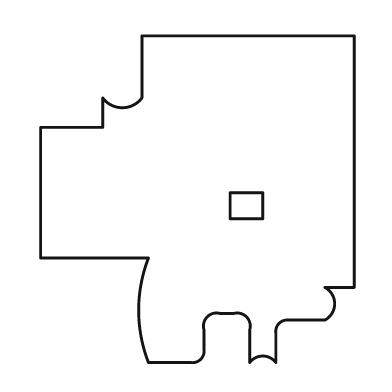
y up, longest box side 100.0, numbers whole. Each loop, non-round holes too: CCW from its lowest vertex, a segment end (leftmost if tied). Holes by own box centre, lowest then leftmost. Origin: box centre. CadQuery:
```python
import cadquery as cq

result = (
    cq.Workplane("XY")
    .moveTo(-15.0, -50.0)
    .lineTo(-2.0, -50.0)
    .threePointArc((1.0, -49.0), (2.0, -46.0))
    .lineTo(2.0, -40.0)
    .threePointArc((3.0, -36.0), (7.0, -35.0))
    .lineTo(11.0, -35.0)
    .threePointArc((15.0, -36.0), (16.0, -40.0))
    .lineTo(16.0, -50.0)
    .threePointArc((20.0, -48.0), (24.0, -50.0))
    .lineTo(24.0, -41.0)
    .threePointArc((25.0, -38.0), (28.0, -37.0))
    .lineTo(39.0, -37.0)
    .threePointArc((42.0, -32.0), (39.0, -27.0))
    .lineTo(48.0, -27.0)
    .lineTo(48.0, 50.0)
    .lineTo(-17.0, 50.0)
    .lineTo(-17.0, 31.0)
    .threePointArc((-23.0, 28.0), (-29.0, 31.0))
    .lineTo(-29.0, 22.0)
    .lineTo(-48.0, 22.0)
    .lineTo(-48.0, -18.0)
    .lineTo(-15.0, -18.0)
    .threePointArc((-18.0, -34.0), (-15.0, -50.0))
    .close()
    .moveTo(10.0, -6.0)
    .lineTo(20.0, -6.0)
    .lineTo(20.0, 2.0)
    .lineTo(10.0, 2.0)
    .close()
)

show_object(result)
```